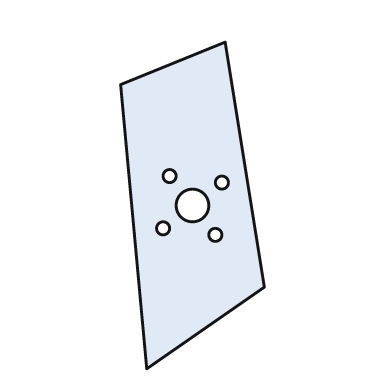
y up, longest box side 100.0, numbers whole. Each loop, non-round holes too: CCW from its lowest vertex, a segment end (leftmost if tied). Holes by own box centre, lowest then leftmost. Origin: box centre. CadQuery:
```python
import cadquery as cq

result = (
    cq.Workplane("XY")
    .moveTo(-14.0, -50.0)
    .lineTo(22.0, -25.0)
    .lineTo(10.0, 50.0)
    .lineTo(-22.0, 37.0)
    .close()
    .moveTo(7.0, -9.0)
    .circle(2.0)
    .moveTo(-9.0, -7.0)
    .circle(2.0)
    .moveTo(0.0, 0.0)
    .circle(5.0)
    .moveTo(9.0, 7.0)
    .circle(2.0)
    .moveTo(-7.0, 9.0)
    .circle(2.0)
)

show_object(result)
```